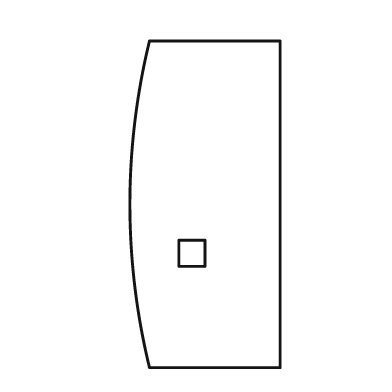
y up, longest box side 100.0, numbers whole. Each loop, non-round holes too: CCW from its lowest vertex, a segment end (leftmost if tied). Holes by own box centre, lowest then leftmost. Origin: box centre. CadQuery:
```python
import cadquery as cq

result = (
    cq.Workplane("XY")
    .moveTo(-17.0, -50.0)
    .lineTo(23.0, -50.0)
    .lineTo(23.0, 50.0)
    .lineTo(-17.0, 50.0)
    .threePointArc((-23.0, 0.0), (-17.0, -50.0))
    .close()
    .moveTo(-8.0, -19.0)
    .lineTo(0.0, -19.0)
    .lineTo(0.0, -11.0)
    .lineTo(-8.0, -11.0)
    .close()
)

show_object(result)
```